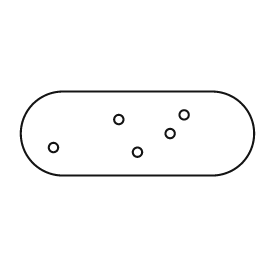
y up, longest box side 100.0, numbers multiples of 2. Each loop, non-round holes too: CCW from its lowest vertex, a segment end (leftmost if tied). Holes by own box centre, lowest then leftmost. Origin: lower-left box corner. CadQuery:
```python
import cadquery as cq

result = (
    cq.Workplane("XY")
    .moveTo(18.0, 0.0)
    .lineTo(82.0, 0.0)
    .threePointArc((100.0, 18.0), (82.0, 36.0))
    .lineTo(18.0, 36.0)
    .threePointArc((0.0, 18.0), (18.0, 0.0))
    .close()
    .moveTo(50.0, 10.0)
    .circle(2.0)
    .moveTo(14.0, 12.0)
    .circle(2.0)
    .moveTo(64.0, 18.0)
    .circle(2.0)
    .moveTo(42.0, 24.0)
    .circle(2.0)
    .moveTo(70.0, 26.0)
    .circle(2.0)
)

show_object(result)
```